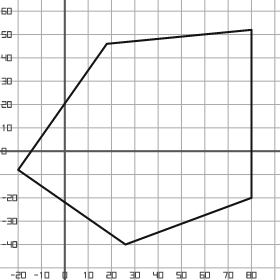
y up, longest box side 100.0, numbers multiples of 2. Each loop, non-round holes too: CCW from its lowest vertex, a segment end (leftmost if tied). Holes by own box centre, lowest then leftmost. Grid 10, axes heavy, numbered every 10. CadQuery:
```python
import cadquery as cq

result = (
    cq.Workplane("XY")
    .moveTo(26.0, -40.0)
    .lineTo(80.0, -20.0)
    .lineTo(80.0, 52.0)
    .lineTo(18.0, 46.0)
    .lineTo(-20.0, -8.0)
    .close()
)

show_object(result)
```